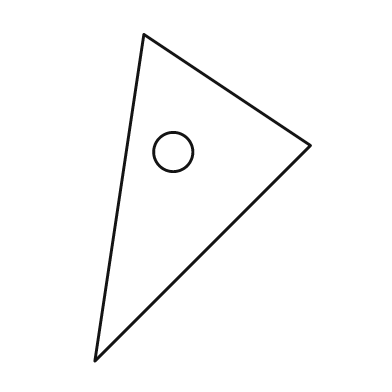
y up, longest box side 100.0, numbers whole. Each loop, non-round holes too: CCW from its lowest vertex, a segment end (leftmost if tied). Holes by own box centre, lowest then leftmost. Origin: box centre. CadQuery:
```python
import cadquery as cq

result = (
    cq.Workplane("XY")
    .moveTo(-33.0, -50.0)
    .lineTo(33.0, 16.0)
    .lineTo(-18.0, 50.0)
    .close()
    .moveTo(-9.0, 14.0)
    .circle(6.0)
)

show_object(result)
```